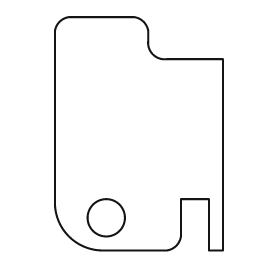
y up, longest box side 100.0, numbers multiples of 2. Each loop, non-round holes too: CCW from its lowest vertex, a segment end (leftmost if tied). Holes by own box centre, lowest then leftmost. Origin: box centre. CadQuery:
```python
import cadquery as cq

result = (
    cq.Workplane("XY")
    .moveTo(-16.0, -50.0)
    .lineTo(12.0, -50.0)
    .threePointArc((16.0, -48.0), (18.0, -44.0))
    .lineTo(18.0, -28.0)
    .lineTo(30.0, -28.0)
    .lineTo(30.0, -50.0)
    .lineTo(36.0, -50.0)
    .lineTo(36.0, 32.0)
    .lineTo(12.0, 32.0)
    .threePointArc((6.0, 34.0), (4.0, 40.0))
    .lineTo(4.0, 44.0)
    .threePointArc((2.0, 48.0), (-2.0, 50.0))
    .lineTo(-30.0, 50.0)
    .threePointArc((-34.0, 48.0), (-36.0, 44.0))
    .lineTo(-36.0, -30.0)
    .threePointArc((-30.0, -44.0), (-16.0, -50.0))
    .close()
    .moveTo(-14.0, -36.0)
    .circle(8.0)
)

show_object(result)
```